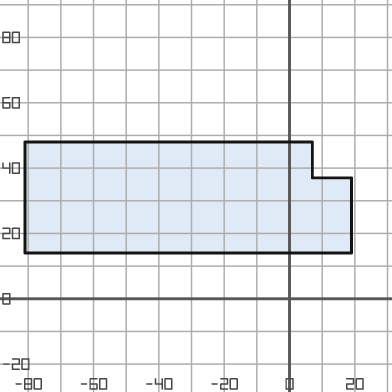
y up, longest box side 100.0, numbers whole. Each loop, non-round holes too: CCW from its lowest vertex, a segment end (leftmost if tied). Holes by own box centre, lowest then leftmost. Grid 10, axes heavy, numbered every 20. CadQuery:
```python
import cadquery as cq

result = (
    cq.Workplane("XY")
    .moveTo(-81.0, 14.0)
    .lineTo(19.0, 14.0)
    .lineTo(19.0, 37.0)
    .lineTo(7.0, 37.0)
    .lineTo(7.0, 48.0)
    .lineTo(-81.0, 48.0)
    .close()
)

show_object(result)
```